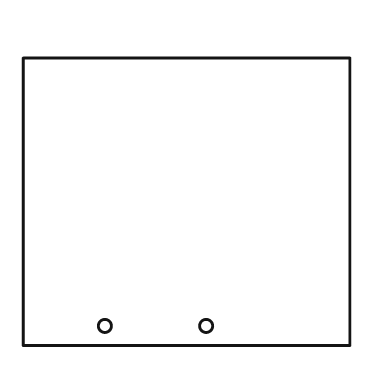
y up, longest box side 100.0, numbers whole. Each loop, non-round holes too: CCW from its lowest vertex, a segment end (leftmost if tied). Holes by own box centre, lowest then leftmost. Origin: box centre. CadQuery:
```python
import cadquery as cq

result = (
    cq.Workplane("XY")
    .moveTo(-50.0, -44.0)
    .lineTo(50.0, -44.0)
    .lineTo(50.0, 44.0)
    .lineTo(-50.0, 44.0)
    .close()
    .moveTo(-25.0, -38.0)
    .circle(2.0)
    .moveTo(6.0, -38.0)
    .circle(2.0)
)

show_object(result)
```